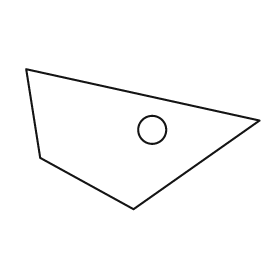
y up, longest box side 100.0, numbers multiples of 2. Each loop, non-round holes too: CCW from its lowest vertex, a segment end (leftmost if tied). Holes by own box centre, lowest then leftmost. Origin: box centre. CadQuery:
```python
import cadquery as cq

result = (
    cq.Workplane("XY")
    .moveTo(-4.0, -30.0)
    .lineTo(50.0, 8.0)
    .lineTo(-50.0, 30.0)
    .lineTo(-44.0, -8.0)
    .close()
    .moveTo(4.0, 4.0)
    .circle(6.0)
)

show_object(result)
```